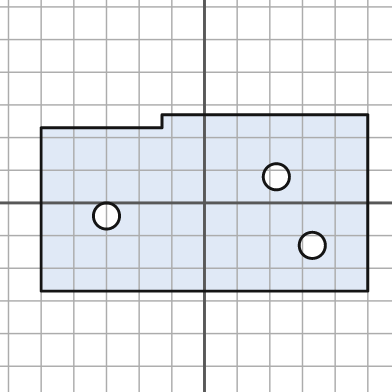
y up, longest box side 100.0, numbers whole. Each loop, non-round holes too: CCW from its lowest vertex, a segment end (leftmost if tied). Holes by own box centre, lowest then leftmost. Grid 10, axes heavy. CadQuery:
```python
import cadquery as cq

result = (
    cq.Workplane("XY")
    .moveTo(-50.0, -27.0)
    .lineTo(50.0, -27.0)
    .lineTo(50.0, 27.0)
    .lineTo(-13.0, 27.0)
    .lineTo(-13.0, 23.0)
    .lineTo(-50.0, 23.0)
    .close()
    .moveTo(33.0, -13.0)
    .circle(4.0)
    .moveTo(-30.0, -4.0)
    .circle(4.0)
    .moveTo(22.0, 8.0)
    .circle(4.0)
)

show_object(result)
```